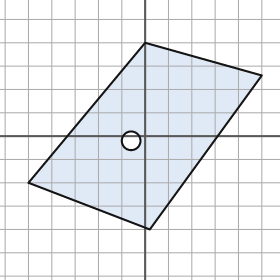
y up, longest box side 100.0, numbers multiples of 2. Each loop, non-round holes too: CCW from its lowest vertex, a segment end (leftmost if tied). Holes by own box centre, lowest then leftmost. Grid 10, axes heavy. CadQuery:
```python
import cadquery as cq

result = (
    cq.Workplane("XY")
    .moveTo(2.0, -40.0)
    .lineTo(50.0, 26.0)
    .lineTo(0.0, 40.0)
    .lineTo(-50.0, -20.0)
    .close()
    .moveTo(-6.0, -2.0)
    .circle(4.0)
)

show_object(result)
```